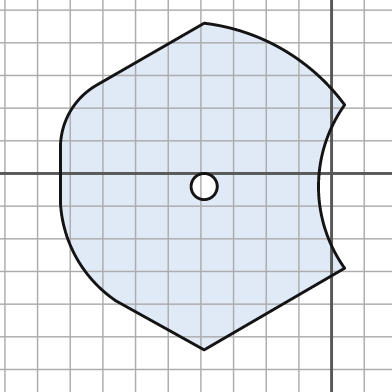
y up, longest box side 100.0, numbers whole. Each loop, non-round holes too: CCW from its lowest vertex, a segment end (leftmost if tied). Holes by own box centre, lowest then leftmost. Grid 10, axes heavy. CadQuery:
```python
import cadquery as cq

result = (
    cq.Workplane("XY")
    .moveTo(-39.0, -54.0)
    .lineTo(4.0, -29.0)
    .threePointArc((-4.0, -4.0), (4.0, 21.0))
    .threePointArc((-15.0, 38.0), (-39.0, 46.0))
    .lineTo(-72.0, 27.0)
    .threePointArc((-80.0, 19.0), (-83.0, 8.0))
    .lineTo(-83.0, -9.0)
    .threePointArc((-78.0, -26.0), (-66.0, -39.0))
    .close()
    .moveTo(-39.0, -4.0)
    .circle(4.0)
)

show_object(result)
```